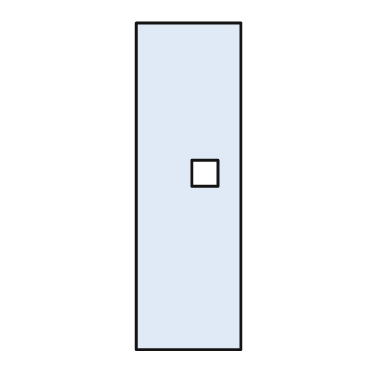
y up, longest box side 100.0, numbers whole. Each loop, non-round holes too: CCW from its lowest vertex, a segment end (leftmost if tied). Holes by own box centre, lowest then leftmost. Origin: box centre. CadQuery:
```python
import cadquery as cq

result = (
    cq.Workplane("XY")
    .moveTo(-16.0, -50.0)
    .lineTo(16.0, -50.0)
    .lineTo(16.0, 50.0)
    .lineTo(-16.0, 50.0)
    .close()
    .moveTo(1.0, 0.0)
    .lineTo(9.0, 0.0)
    .lineTo(9.0, 8.0)
    .lineTo(1.0, 8.0)
    .close()
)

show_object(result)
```